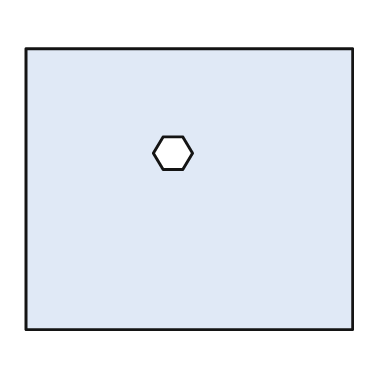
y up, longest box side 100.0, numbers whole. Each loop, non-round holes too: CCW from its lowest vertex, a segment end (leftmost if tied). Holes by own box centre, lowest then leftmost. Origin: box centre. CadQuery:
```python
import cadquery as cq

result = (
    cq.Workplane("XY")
    .moveTo(-50.0, -43.0)
    .lineTo(50.0, -43.0)
    .lineTo(50.0, 43.0)
    .lineTo(-50.0, 43.0)
    .close()
    .moveTo(-8.0, 6.0)
    .lineTo(-2.0, 6.0)
    .lineTo(1.0, 11.0)
    .lineTo(-2.0, 16.0)
    .lineTo(-8.0, 16.0)
    .lineTo(-11.0, 11.0)
    .close()
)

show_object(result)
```